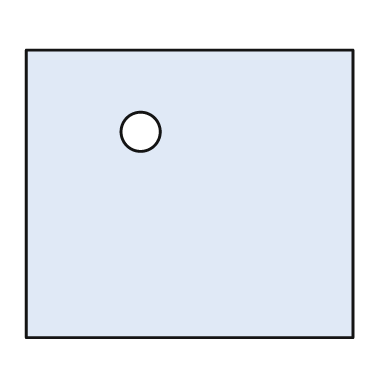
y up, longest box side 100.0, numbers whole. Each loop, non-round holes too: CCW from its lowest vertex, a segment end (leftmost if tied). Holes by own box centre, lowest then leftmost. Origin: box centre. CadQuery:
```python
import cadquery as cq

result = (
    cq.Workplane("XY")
    .moveTo(-50.0, -44.0)
    .lineTo(50.0, -44.0)
    .lineTo(50.0, 44.0)
    .lineTo(-50.0, 44.0)
    .close()
    .moveTo(-15.0, 19.0)
    .circle(6.0)
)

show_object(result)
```